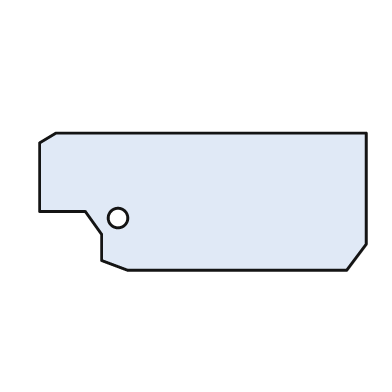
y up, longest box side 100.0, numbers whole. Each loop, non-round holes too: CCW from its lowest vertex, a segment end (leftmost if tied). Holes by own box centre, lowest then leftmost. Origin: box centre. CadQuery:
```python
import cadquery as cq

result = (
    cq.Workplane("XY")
    .moveTo(-23.0, -21.0)
    .lineTo(44.0, -21.0)
    .lineTo(50.0, -13.0)
    .lineTo(50.0, 21.0)
    .lineTo(-45.0, 21.0)
    .lineTo(-50.0, 18.0)
    .lineTo(-50.0, -3.0)
    .lineTo(-36.0, -3.0)
    .lineTo(-31.0, -10.0)
    .lineTo(-31.0, -18.0)
    .close()
    .moveTo(-26.0, -5.0)
    .circle(3.0)
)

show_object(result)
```